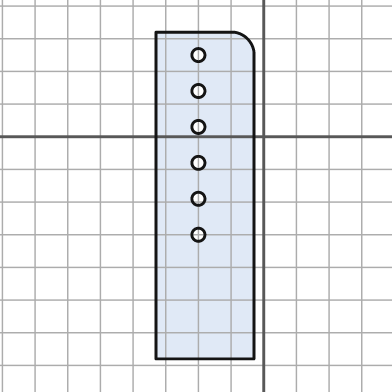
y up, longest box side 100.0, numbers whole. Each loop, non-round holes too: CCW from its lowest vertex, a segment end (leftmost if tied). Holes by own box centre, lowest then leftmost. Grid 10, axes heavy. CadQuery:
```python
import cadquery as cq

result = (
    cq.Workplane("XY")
    .moveTo(-33.0, -68.0)
    .lineTo(-3.0, -68.0)
    .lineTo(-3.0, 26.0)
    .threePointArc((-5.0, 30.0), (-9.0, 32.0))
    .lineTo(-33.0, 32.0)
    .close()
    .moveTo(-20.0, -30.0)
    .circle(2.0)
    .moveTo(-20.0, -19.0)
    .circle(2.0)
    .moveTo(-20.0, -8.0)
    .circle(2.0)
    .moveTo(-20.0, 3.0)
    .circle(2.0)
    .moveTo(-20.0, 14.0)
    .circle(2.0)
    .moveTo(-20.0, 25.0)
    .circle(2.0)
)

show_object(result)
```